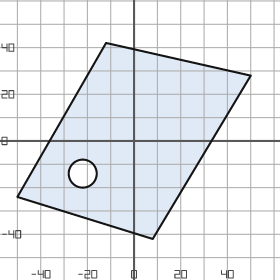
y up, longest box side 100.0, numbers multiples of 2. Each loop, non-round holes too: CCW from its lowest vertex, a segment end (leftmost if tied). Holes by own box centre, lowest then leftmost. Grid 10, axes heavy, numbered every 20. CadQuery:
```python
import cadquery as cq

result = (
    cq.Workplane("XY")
    .moveTo(8.0, -42.0)
    .lineTo(50.0, 28.0)
    .lineTo(-12.0, 42.0)
    .lineTo(-50.0, -24.0)
    .close()
    .moveTo(-22.0, -14.0)
    .circle(6.0)
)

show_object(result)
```